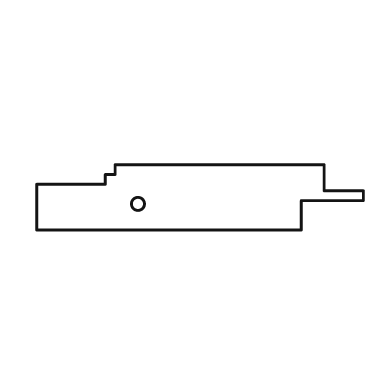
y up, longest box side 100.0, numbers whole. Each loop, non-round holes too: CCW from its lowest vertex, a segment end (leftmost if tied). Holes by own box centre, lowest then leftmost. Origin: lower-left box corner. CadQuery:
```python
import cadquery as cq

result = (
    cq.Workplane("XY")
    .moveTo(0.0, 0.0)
    .lineTo(81.0, 0.0)
    .lineTo(81.0, 9.0)
    .lineTo(100.0, 9.0)
    .lineTo(100.0, 12.0)
    .lineTo(88.0, 12.0)
    .lineTo(88.0, 20.0)
    .lineTo(24.0, 20.0)
    .lineTo(24.0, 17.0)
    .lineTo(21.0, 17.0)
    .lineTo(21.0, 14.0)
    .lineTo(0.0, 14.0)
    .close()
    .moveTo(31.0, 8.0)
    .circle(2.0)
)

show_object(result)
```